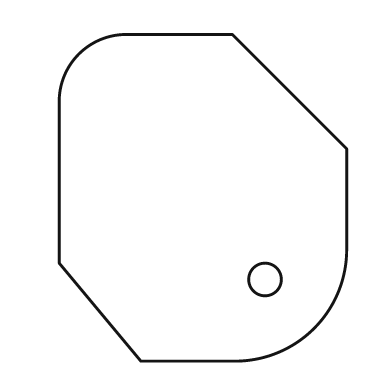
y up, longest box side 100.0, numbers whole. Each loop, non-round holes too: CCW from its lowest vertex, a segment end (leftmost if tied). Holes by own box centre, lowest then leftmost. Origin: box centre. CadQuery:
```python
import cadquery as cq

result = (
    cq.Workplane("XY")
    .moveTo(-19.0, -50.0)
    .lineTo(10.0, -50.0)
    .threePointArc((34.0, -40.0), (44.0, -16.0))
    .lineTo(44.0, 15.0)
    .lineTo(9.0, 50.0)
    .lineTo(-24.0, 50.0)
    .threePointArc((-38.0, 44.0), (-44.0, 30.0))
    .lineTo(-44.0, -20.0)
    .close()
    .moveTo(19.0, -25.0)
    .circle(5.0)
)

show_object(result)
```